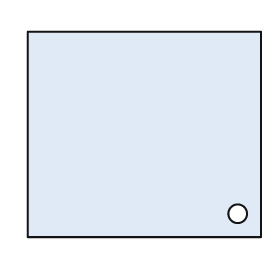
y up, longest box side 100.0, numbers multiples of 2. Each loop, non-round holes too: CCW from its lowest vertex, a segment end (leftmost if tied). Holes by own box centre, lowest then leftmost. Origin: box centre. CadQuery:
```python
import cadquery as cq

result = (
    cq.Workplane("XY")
    .moveTo(-50.0, -44.0)
    .lineTo(50.0, -44.0)
    .lineTo(50.0, 44.0)
    .lineTo(-50.0, 44.0)
    .close()
    .moveTo(40.0, -34.0)
    .circle(4.0)
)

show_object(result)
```